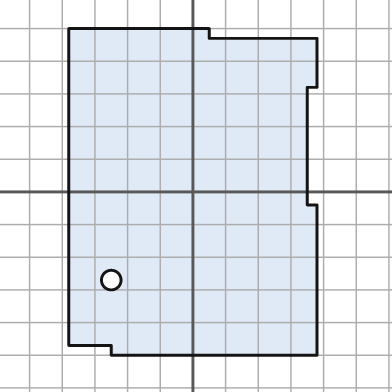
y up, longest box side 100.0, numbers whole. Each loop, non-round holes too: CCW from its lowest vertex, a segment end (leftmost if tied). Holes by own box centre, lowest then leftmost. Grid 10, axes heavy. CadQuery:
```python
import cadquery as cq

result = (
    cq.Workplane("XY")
    .moveTo(-25.0, -50.0)
    .lineTo(38.0, -50.0)
    .lineTo(38.0, -4.0)
    .lineTo(35.0, -4.0)
    .lineTo(35.0, 32.0)
    .lineTo(38.0, 32.0)
    .lineTo(38.0, 47.0)
    .lineTo(5.0, 47.0)
    .lineTo(5.0, 50.0)
    .lineTo(-38.0, 50.0)
    .lineTo(-38.0, -47.0)
    .lineTo(-25.0, -47.0)
    .close()
    .moveTo(-25.0, -27.0)
    .circle(3.0)
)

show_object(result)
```